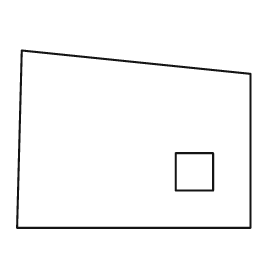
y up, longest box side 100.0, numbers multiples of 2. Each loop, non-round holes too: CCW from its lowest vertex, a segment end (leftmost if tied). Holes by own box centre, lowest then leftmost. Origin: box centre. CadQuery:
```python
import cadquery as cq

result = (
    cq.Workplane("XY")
    .moveTo(-50.0, -38.0)
    .lineTo(50.0, -38.0)
    .lineTo(50.0, 28.0)
    .lineTo(-48.0, 38.0)
    .close()
    .moveTo(18.0, -22.0)
    .lineTo(34.0, -22.0)
    .lineTo(34.0, -6.0)
    .lineTo(18.0, -6.0)
    .close()
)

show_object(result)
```